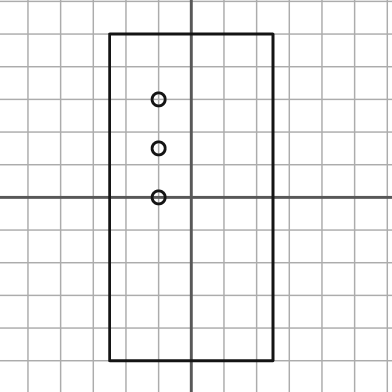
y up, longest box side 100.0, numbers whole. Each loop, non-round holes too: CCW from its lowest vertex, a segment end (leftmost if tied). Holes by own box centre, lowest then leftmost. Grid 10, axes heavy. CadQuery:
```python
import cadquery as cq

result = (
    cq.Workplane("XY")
    .moveTo(-25.0, -50.0)
    .lineTo(25.0, -50.0)
    .lineTo(25.0, 50.0)
    .lineTo(-25.0, 50.0)
    .close()
    .moveTo(-10.0, 0.0)
    .circle(2.0)
    .moveTo(-10.0, 15.0)
    .circle(2.0)
    .moveTo(-10.0, 30.0)
    .circle(2.0)
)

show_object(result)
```